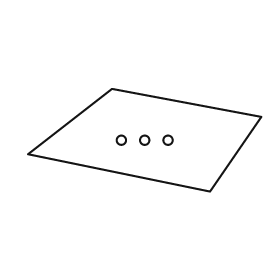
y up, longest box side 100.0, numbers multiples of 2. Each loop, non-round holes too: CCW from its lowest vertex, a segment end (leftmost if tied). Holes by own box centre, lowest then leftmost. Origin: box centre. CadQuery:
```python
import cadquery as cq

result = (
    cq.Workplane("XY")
    .moveTo(28.0, -22.0)
    .lineTo(50.0, 10.0)
    .lineTo(-14.0, 22.0)
    .lineTo(-50.0, -6.0)
    .close()
    .moveTo(-10.0, 0.0)
    .circle(2.0)
    .moveTo(0.0, 0.0)
    .circle(2.0)
    .moveTo(10.0, 0.0)
    .circle(2.0)
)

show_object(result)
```